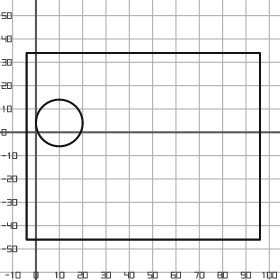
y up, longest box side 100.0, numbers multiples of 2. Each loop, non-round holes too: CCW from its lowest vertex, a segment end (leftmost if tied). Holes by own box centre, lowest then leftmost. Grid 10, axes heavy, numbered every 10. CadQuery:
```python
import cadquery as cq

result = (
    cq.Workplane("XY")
    .moveTo(-4.0, -46.0)
    .lineTo(96.0, -46.0)
    .lineTo(96.0, 34.0)
    .lineTo(-4.0, 34.0)
    .close()
    .moveTo(10.0, 4.0)
    .circle(10.0)
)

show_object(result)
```